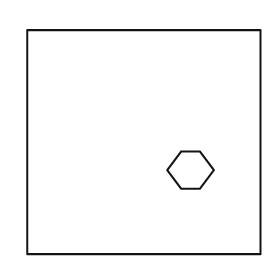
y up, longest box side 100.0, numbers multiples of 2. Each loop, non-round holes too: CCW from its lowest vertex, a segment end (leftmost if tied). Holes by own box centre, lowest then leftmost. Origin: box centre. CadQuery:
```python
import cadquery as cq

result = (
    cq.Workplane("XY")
    .moveTo(-50.0, -48.0)
    .lineTo(50.0, -48.0)
    .lineTo(50.0, 48.0)
    .lineTo(-50.0, 48.0)
    .close()
    .moveTo(16.0, -20.0)
    .lineTo(24.0, -20.0)
    .lineTo(30.0, -12.0)
    .lineTo(24.0, -4.0)
    .lineTo(16.0, -4.0)
    .lineTo(10.0, -12.0)
    .close()
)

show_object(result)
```